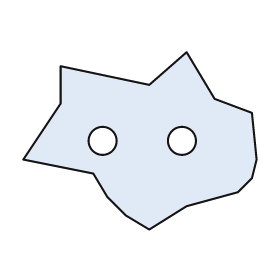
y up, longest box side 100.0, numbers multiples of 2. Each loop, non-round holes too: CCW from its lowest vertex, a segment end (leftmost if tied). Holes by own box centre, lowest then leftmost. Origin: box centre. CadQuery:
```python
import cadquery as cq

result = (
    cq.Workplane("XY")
    .moveTo(4.0, -38.0)
    .lineTo(20.0, -28.0)
    .lineTo(42.0, -22.0)
    .lineTo(48.0, -16.0)
    .lineTo(50.0, -8.0)
    .lineTo(48.0, 12.0)
    .lineTo(32.0, 18.0)
    .lineTo(20.0, 38.0)
    .lineTo(4.0, 24.0)
    .lineTo(-34.0, 32.0)
    .lineTo(-34.0, 16.0)
    .lineTo(-50.0, -8.0)
    .lineTo(-20.0, -14.0)
    .lineTo(-14.0, -24.0)
    .lineTo(-6.0, -32.0)
    .close()
    .moveTo(-16.0, 0.0)
    .circle(6.0)
    .moveTo(18.0, 0.0)
    .circle(6.0)
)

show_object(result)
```